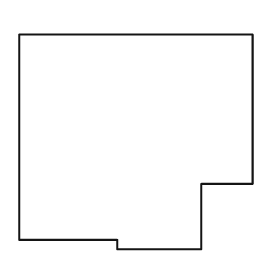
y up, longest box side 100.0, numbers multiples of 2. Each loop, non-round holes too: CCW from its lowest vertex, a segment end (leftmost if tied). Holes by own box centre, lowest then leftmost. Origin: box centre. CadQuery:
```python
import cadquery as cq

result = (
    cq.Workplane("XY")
    .moveTo(-8.0, -46.0)
    .lineTo(28.0, -46.0)
    .lineTo(28.0, -18.0)
    .lineTo(50.0, -18.0)
    .lineTo(50.0, 46.0)
    .lineTo(-50.0, 46.0)
    .lineTo(-50.0, -42.0)
    .lineTo(-8.0, -42.0)
    .close()
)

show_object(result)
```